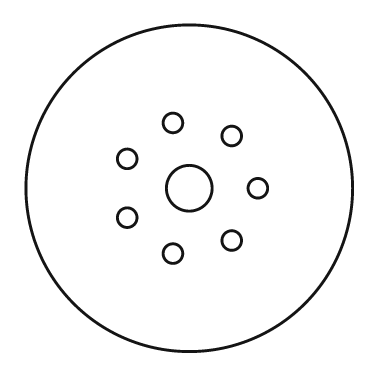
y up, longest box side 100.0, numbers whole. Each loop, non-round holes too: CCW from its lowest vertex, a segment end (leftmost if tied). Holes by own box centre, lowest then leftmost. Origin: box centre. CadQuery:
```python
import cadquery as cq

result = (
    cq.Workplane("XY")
    .moveTo(0.0, 0.0)
    .circle(50.0)
    .moveTo(-5.0, -20.0)
    .circle(3.0)
    .moveTo(13.0, -16.0)
    .circle(3.0)
    .moveTo(-19.0, -9.0)
    .circle(3.0)
    .moveTo(0.0, 0.0)
    .circle(7.0)
    .moveTo(21.0, 0.0)
    .circle(3.0)
    .moveTo(-19.0, 9.0)
    .circle(3.0)
    .moveTo(13.0, 16.0)
    .circle(3.0)
    .moveTo(-5.0, 20.0)
    .circle(3.0)
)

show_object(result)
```